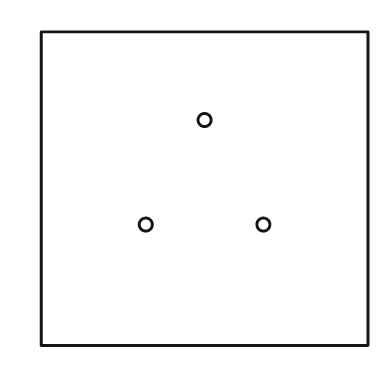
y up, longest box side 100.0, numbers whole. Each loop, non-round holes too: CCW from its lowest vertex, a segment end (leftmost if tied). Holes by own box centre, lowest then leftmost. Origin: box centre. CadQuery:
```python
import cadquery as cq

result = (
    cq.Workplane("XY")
    .moveTo(-50.0, -48.0)
    .lineTo(50.0, -48.0)
    .lineTo(50.0, 48.0)
    .lineTo(-50.0, 48.0)
    .close()
    .moveTo(-18.0, -11.0)
    .circle(2.0)
    .moveTo(18.0, -11.0)
    .circle(2.0)
    .moveTo(0.0, 21.0)
    .circle(2.0)
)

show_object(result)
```